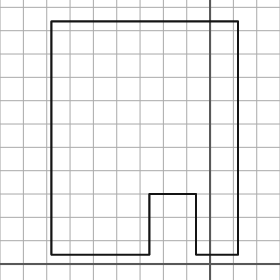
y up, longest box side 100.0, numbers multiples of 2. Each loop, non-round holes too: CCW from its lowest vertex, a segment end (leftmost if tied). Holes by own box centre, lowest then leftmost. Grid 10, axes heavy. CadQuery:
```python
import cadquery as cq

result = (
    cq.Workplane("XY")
    .moveTo(-68.0, 4.0)
    .lineTo(-26.0, 4.0)
    .lineTo(-26.0, 30.0)
    .lineTo(-6.0, 30.0)
    .lineTo(-6.0, 4.0)
    .lineTo(12.0, 4.0)
    .lineTo(12.0, 104.0)
    .lineTo(-68.0, 104.0)
    .close()
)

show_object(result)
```